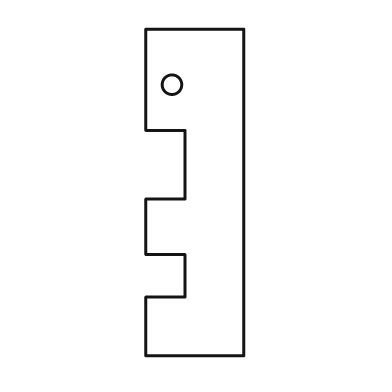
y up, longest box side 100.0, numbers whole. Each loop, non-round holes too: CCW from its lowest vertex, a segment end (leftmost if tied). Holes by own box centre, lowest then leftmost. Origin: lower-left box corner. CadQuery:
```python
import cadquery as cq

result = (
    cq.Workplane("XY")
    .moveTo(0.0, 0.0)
    .lineTo(30.0, 0.0)
    .lineTo(30.0, 100.0)
    .lineTo(0.0, 100.0)
    .lineTo(0.0, 69.0)
    .lineTo(12.0, 69.0)
    .lineTo(12.0, 48.0)
    .lineTo(0.0, 48.0)
    .lineTo(0.0, 31.0)
    .lineTo(12.0, 31.0)
    .lineTo(12.0, 18.0)
    .lineTo(0.0, 18.0)
    .close()
    .moveTo(8.0, 83.0)
    .circle(3.0)
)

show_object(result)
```